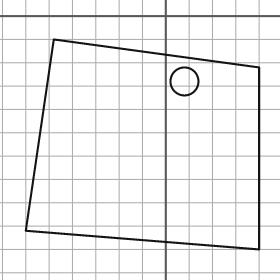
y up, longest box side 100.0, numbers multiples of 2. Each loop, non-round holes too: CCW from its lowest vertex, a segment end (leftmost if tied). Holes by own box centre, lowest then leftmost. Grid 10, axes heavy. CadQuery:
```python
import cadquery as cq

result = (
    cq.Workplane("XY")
    .moveTo(40.0, -100.0)
    .lineTo(40.0, -22.0)
    .lineTo(-48.0, -10.0)
    .lineTo(-60.0, -92.0)
    .close()
    .moveTo(8.0, -28.0)
    .circle(6.0)
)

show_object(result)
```